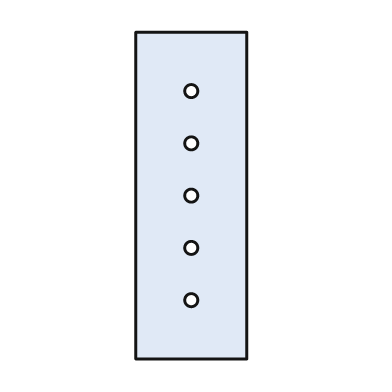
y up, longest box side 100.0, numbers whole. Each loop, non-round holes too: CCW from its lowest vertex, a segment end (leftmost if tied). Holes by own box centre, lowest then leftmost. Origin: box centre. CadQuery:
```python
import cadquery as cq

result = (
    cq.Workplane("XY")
    .moveTo(-17.0, -50.0)
    .lineTo(17.0, -50.0)
    .lineTo(17.0, 50.0)
    .lineTo(-17.0, 50.0)
    .close()
    .moveTo(0.0, -32.0)
    .circle(2.0)
    .moveTo(0.0, -16.0)
    .circle(2.0)
    .moveTo(0.0, 0.0)
    .circle(2.0)
    .moveTo(0.0, 16.0)
    .circle(2.0)
    .moveTo(0.0, 32.0)
    .circle(2.0)
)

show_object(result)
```